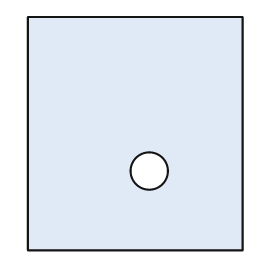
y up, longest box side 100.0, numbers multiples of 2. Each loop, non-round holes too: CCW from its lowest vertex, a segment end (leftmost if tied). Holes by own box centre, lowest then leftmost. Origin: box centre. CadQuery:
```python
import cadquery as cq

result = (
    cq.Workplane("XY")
    .moveTo(-46.0, -50.0)
    .lineTo(46.0, -50.0)
    .lineTo(46.0, 50.0)
    .lineTo(-46.0, 50.0)
    .close()
    .moveTo(6.0, -16.0)
    .circle(8.0)
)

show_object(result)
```